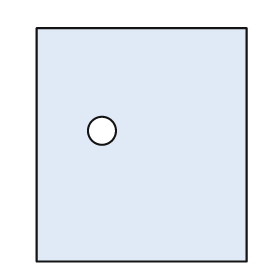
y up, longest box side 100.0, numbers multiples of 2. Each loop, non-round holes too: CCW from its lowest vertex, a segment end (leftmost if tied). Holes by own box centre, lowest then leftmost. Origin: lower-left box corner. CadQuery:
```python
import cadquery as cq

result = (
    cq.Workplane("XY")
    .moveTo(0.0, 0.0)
    .lineTo(90.0, 0.0)
    .lineTo(90.0, 100.0)
    .lineTo(0.0, 100.0)
    .close()
    .moveTo(28.0, 56.0)
    .circle(6.0)
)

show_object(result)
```